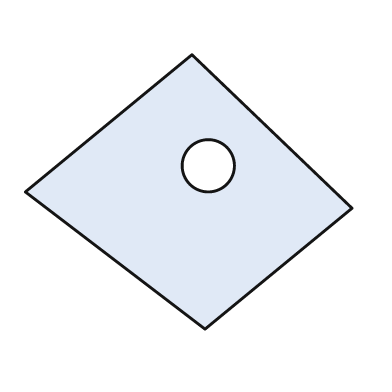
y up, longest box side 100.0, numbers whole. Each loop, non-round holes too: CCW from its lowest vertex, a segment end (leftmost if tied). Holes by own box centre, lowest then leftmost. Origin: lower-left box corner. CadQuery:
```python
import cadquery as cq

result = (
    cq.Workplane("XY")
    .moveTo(55.0, 0.0)
    .lineTo(100.0, 37.0)
    .lineTo(51.0, 84.0)
    .lineTo(0.0, 42.0)
    .close()
    .moveTo(56.0, 50.0)
    .circle(8.0)
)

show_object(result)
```